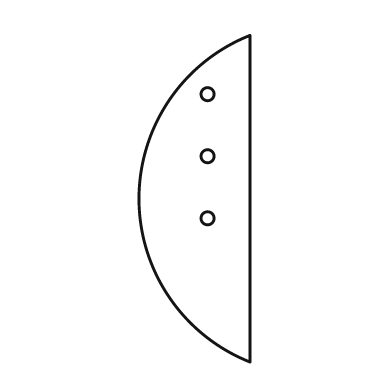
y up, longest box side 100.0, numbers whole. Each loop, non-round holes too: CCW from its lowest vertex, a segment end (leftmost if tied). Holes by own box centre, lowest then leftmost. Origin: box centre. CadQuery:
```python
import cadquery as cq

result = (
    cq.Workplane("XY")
    .moveTo(17.0, -50.0)
    .lineTo(17.0, 50.0)
    .threePointArc((-17.0, 0.0), (17.0, -50.0))
    .close()
    .moveTo(4.0, -6.0)
    .circle(2.0)
    .moveTo(4.0, 13.0)
    .circle(2.0)
    .moveTo(4.0, 32.0)
    .circle(2.0)
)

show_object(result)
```